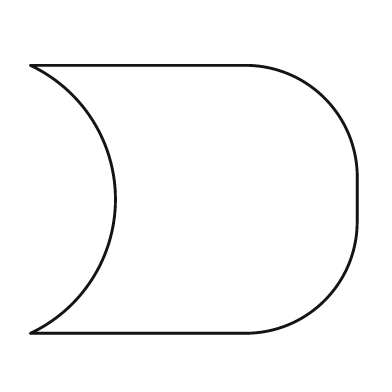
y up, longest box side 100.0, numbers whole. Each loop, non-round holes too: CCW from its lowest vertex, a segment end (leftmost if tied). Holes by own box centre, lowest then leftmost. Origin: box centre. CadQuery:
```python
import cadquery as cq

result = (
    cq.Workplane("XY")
    .moveTo(-50.0, -41.0)
    .lineTo(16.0, -41.0)
    .threePointArc((40.0, -31.0), (50.0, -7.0))
    .lineTo(50.0, 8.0)
    .threePointArc((40.0, 31.0), (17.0, 41.0))
    .lineTo(-50.0, 41.0)
    .threePointArc((-24.0, 0.0), (-50.0, -41.0))
    .close()
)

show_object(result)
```